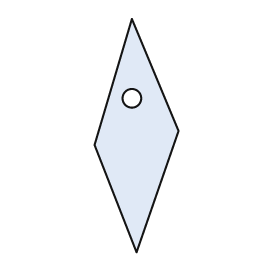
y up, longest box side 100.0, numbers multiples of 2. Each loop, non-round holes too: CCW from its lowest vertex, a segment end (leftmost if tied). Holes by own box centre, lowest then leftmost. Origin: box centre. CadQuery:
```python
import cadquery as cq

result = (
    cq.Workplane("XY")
    .moveTo(0.0, -50.0)
    .lineTo(18.0, 2.0)
    .lineTo(-2.0, 50.0)
    .lineTo(-18.0, -4.0)
    .close()
    .moveTo(-2.0, 16.0)
    .circle(4.0)
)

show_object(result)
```